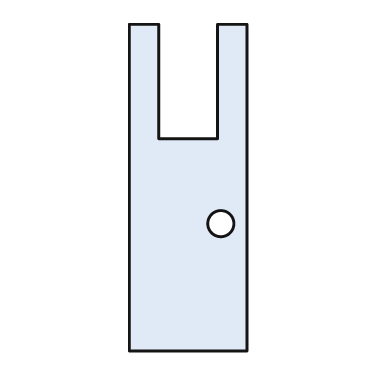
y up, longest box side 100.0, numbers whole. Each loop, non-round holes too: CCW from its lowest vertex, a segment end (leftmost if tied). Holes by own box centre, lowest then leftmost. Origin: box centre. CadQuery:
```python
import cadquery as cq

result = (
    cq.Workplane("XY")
    .moveTo(-18.0, -50.0)
    .lineTo(18.0, -50.0)
    .lineTo(18.0, 50.0)
    .lineTo(9.0, 50.0)
    .lineTo(9.0, 15.0)
    .lineTo(-9.0, 15.0)
    .lineTo(-9.0, 50.0)
    .lineTo(-18.0, 50.0)
    .close()
    .moveTo(10.0, -11.0)
    .circle(4.0)
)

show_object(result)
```